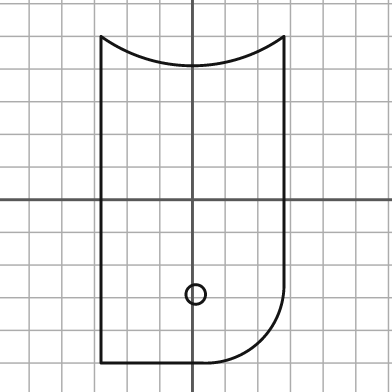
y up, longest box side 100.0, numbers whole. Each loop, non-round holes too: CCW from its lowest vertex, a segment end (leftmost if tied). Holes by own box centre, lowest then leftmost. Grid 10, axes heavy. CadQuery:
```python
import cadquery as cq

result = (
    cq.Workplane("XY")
    .moveTo(-28.0, -50.0)
    .lineTo(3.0, -50.0)
    .threePointArc((21.0, -43.0), (28.0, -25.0))
    .lineTo(28.0, 50.0)
    .threePointArc((0.0, 41.0), (-28.0, 50.0))
    .close()
    .moveTo(1.0, -29.0)
    .circle(3.0)
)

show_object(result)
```